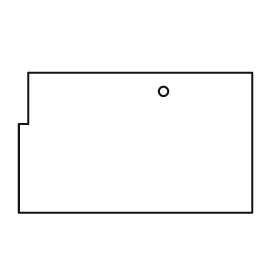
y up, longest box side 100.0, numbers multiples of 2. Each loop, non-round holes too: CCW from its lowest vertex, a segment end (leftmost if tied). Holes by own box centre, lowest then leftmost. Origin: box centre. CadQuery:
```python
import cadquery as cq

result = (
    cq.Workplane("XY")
    .moveTo(-50.0, -30.0)
    .lineTo(50.0, -30.0)
    .lineTo(50.0, 30.0)
    .lineTo(-46.0, 30.0)
    .lineTo(-46.0, 8.0)
    .lineTo(-50.0, 8.0)
    .close()
    .moveTo(12.0, 22.0)
    .circle(2.0)
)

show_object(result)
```